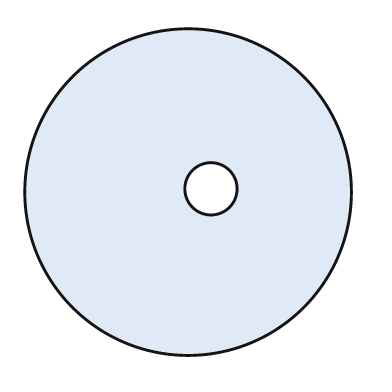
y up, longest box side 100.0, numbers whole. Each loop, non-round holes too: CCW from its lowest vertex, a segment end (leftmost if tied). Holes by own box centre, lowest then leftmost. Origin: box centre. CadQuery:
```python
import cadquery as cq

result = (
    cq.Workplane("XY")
    .moveTo(0.0, 0.0)
    .circle(50.0)
    .moveTo(7.0, 1.0)
    .circle(8.0)
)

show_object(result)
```